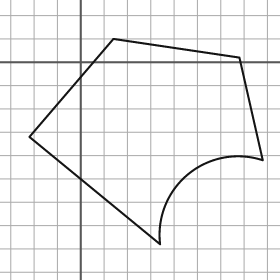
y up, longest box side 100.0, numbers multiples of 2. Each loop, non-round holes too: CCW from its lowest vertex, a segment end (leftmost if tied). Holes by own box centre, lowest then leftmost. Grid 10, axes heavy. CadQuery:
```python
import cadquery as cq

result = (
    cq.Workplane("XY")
    .moveTo(34.0, -78.0)
    .threePointArc((46.0, -48.0), (78.0, -42.0))
    .lineTo(68.0, 2.0)
    .lineTo(14.0, 10.0)
    .lineTo(-22.0, -32.0)
    .close()
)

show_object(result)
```